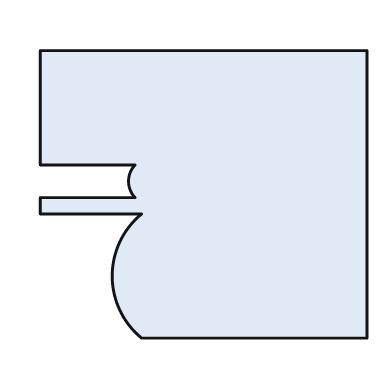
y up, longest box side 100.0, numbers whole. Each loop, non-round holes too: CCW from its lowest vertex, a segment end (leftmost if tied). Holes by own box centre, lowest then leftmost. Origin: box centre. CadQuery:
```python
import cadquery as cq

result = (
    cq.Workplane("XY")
    .moveTo(-19.0, -44.0)
    .lineTo(50.0, -44.0)
    .lineTo(50.0, 44.0)
    .lineTo(-50.0, 44.0)
    .lineTo(-50.0, 9.0)
    .lineTo(-21.0, 9.0)
    .threePointArc((-23.0, 4.0), (-21.0, -1.0))
    .lineTo(-50.0, -1.0)
    .lineTo(-50.0, -6.0)
    .lineTo(-19.0, -6.0)
    .threePointArc((-28.0, -25.0), (-19.0, -44.0))
    .close()
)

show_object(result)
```